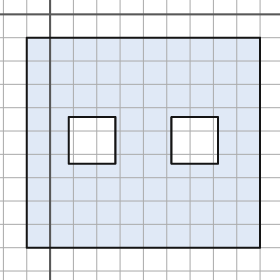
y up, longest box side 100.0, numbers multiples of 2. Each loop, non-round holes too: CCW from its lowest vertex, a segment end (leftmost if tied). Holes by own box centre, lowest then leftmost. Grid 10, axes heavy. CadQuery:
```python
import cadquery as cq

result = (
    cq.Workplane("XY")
    .moveTo(-10.0, -100.0)
    .lineTo(90.0, -100.0)
    .lineTo(90.0, -10.0)
    .lineTo(-10.0, -10.0)
    .close()
    .moveTo(8.0, -64.0)
    .lineTo(28.0, -64.0)
    .lineTo(28.0, -44.0)
    .lineTo(8.0, -44.0)
    .close()
    .moveTo(52.0, -64.0)
    .lineTo(72.0, -64.0)
    .lineTo(72.0, -44.0)
    .lineTo(52.0, -44.0)
    .close()
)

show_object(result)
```